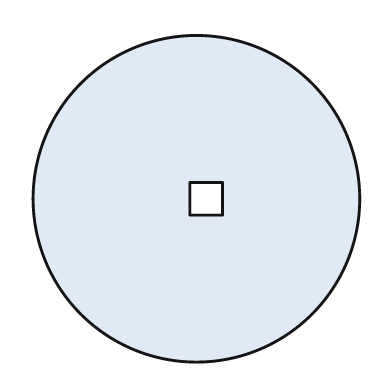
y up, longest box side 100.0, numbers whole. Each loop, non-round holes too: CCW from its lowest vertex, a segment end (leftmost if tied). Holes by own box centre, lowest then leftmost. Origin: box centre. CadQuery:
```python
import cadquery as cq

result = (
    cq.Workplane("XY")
    .moveTo(0.0, 0.0)
    .circle(50.0)
    .moveTo(-2.0, -5.0)
    .lineTo(8.0, -5.0)
    .lineTo(8.0, 5.0)
    .lineTo(-2.0, 5.0)
    .close()
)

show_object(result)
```